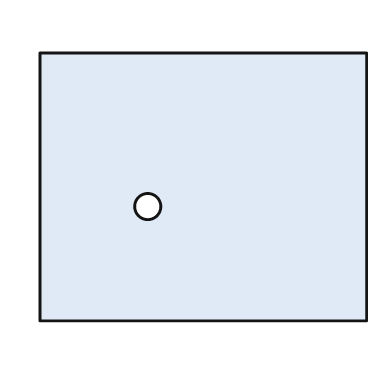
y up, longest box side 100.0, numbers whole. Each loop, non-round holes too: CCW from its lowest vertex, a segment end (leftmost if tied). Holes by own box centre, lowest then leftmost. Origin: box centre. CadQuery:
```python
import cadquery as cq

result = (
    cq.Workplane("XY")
    .moveTo(-50.0, -41.0)
    .lineTo(50.0, -41.0)
    .lineTo(50.0, 41.0)
    .lineTo(-50.0, 41.0)
    .close()
    .moveTo(-17.0, -6.0)
    .circle(4.0)
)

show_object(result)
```